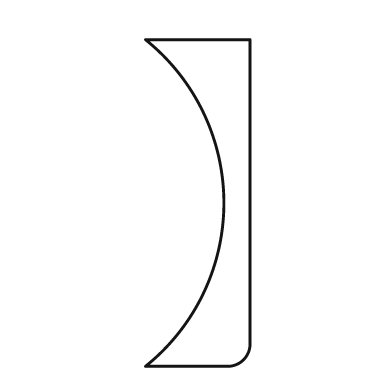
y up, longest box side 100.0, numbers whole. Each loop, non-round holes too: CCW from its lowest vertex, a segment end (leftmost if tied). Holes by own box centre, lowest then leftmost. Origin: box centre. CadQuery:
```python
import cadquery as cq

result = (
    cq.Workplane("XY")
    .moveTo(-16.0, -50.0)
    .lineTo(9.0, -50.0)
    .threePointArc((14.0, -48.0), (16.0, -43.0))
    .lineTo(16.0, 50.0)
    .lineTo(-16.0, 50.0)
    .threePointArc((8.0, 0.0), (-16.0, -50.0))
    .close()
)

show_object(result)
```